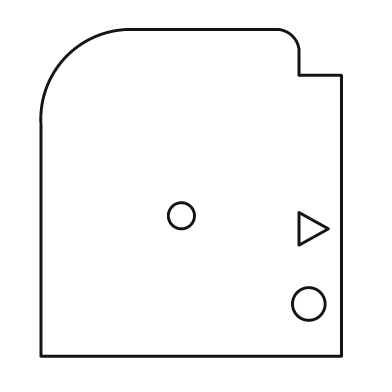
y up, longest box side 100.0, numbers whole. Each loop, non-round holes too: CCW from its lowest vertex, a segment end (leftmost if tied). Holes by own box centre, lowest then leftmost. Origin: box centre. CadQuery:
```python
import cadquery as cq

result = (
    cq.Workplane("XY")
    .moveTo(-46.0, -50.0)
    .lineTo(46.0, -50.0)
    .lineTo(46.0, 36.0)
    .lineTo(33.0, 36.0)
    .lineTo(33.0, 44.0)
    .threePointArc((31.0, 48.0), (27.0, 50.0))
    .lineTo(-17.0, 50.0)
    .threePointArc((-38.0, 42.0), (-46.0, 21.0))
    .close()
    .moveTo(36.0, -34.0)
    .circle(5.0)
    .moveTo(33.0, -16.0)
    .lineTo(42.0, -11.0)
    .lineTo(33.0, -6.0)
    .close()
    .moveTo(-3.0, -7.0)
    .circle(4.0)
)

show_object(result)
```